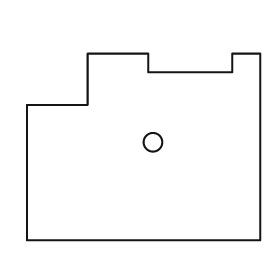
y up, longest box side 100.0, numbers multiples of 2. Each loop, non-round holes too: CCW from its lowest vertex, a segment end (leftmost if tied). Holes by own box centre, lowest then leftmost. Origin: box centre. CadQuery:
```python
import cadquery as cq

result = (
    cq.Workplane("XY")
    .moveTo(-50.0, -40.0)
    .lineTo(50.0, -40.0)
    .lineTo(50.0, 40.0)
    .lineTo(38.0, 40.0)
    .lineTo(38.0, 32.0)
    .lineTo(2.0, 32.0)
    .lineTo(2.0, 40.0)
    .lineTo(-24.0, 40.0)
    .lineTo(-24.0, 18.0)
    .lineTo(-50.0, 18.0)
    .close()
    .moveTo(4.0, 2.0)
    .circle(4.0)
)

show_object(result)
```